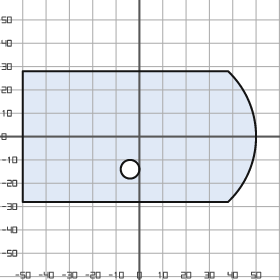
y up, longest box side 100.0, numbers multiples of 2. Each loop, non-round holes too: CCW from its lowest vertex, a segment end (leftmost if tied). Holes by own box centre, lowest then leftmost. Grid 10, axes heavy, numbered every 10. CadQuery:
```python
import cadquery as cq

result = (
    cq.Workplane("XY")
    .moveTo(-50.0, -28.0)
    .lineTo(38.0, -28.0)
    .threePointArc((50.0, 0.0), (38.0, 28.0))
    .lineTo(-50.0, 28.0)
    .close()
    .moveTo(-4.0, -14.0)
    .circle(4.0)
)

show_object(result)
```